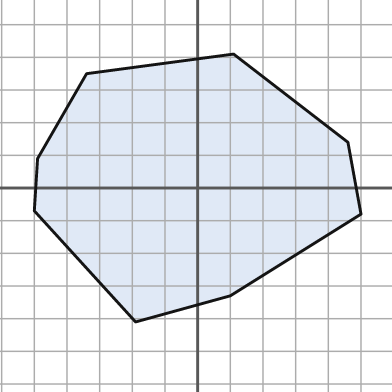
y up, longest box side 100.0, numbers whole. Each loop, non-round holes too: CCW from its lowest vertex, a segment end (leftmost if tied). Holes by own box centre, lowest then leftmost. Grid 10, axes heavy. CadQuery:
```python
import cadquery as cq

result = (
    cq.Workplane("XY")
    .moveTo(-19.0, -41.0)
    .lineTo(10.0, -33.0)
    .lineTo(50.0, -8.0)
    .lineTo(46.0, 14.0)
    .lineTo(11.0, 41.0)
    .lineTo(-34.0, 35.0)
    .lineTo(-49.0, 9.0)
    .lineTo(-50.0, -7.0)
    .close()
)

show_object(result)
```